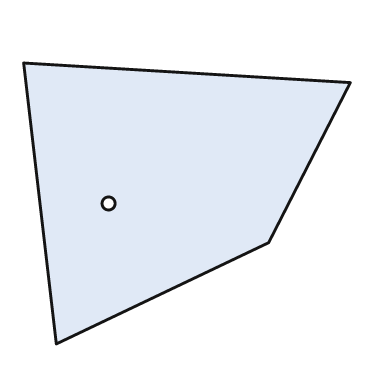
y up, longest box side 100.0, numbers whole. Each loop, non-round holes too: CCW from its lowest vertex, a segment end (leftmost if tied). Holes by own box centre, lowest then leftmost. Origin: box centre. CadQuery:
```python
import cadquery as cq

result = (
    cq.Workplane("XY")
    .moveTo(-40.0, -43.0)
    .lineTo(25.0, -12.0)
    .lineTo(50.0, 37.0)
    .lineTo(-50.0, 43.0)
    .close()
    .moveTo(-24.0, 0.0)
    .circle(2.0)
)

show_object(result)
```